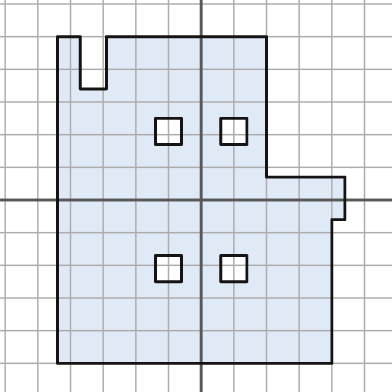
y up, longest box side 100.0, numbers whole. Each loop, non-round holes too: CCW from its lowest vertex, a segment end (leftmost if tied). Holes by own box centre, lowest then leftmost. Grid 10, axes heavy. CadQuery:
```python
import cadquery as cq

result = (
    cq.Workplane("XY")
    .moveTo(-44.0, -50.0)
    .lineTo(40.0, -50.0)
    .lineTo(40.0, -6.0)
    .lineTo(44.0, -6.0)
    .lineTo(44.0, 7.0)
    .lineTo(20.0, 7.0)
    .lineTo(20.0, 50.0)
    .lineTo(-29.0, 50.0)
    .lineTo(-29.0, 34.0)
    .lineTo(-37.0, 34.0)
    .lineTo(-37.0, 50.0)
    .lineTo(-44.0, 50.0)
    .close()
    .moveTo(-14.0, -25.0)
    .lineTo(-6.0, -25.0)
    .lineTo(-6.0, -17.0)
    .lineTo(-14.0, -17.0)
    .close()
    .moveTo(6.0, -25.0)
    .lineTo(14.0, -25.0)
    .lineTo(14.0, -17.0)
    .lineTo(6.0, -17.0)
    .close()
    .moveTo(-14.0, 17.0)
    .lineTo(-6.0, 17.0)
    .lineTo(-6.0, 25.0)
    .lineTo(-14.0, 25.0)
    .close()
    .moveTo(6.0, 17.0)
    .lineTo(14.0, 17.0)
    .lineTo(14.0, 25.0)
    .lineTo(6.0, 25.0)
    .close()
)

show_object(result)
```